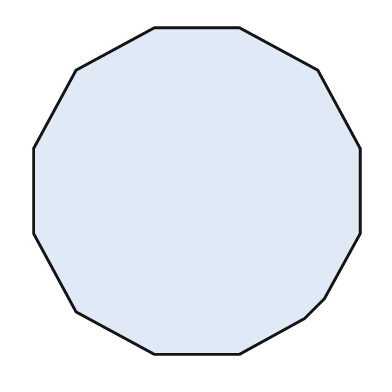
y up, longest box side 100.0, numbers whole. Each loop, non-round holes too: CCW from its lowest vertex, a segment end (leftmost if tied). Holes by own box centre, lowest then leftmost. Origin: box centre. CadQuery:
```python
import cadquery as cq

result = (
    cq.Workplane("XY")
    .moveTo(-13.0, -50.0)
    .lineTo(13.0, -50.0)
    .lineTo(33.0, -39.0)
    .lineTo(39.0, -33.0)
    .lineTo(50.0, -13.0)
    .lineTo(50.0, 13.0)
    .lineTo(37.0, 37.0)
    .lineTo(13.0, 50.0)
    .lineTo(-13.0, 50.0)
    .lineTo(-37.0, 37.0)
    .lineTo(-50.0, 13.0)
    .lineTo(-50.0, -13.0)
    .lineTo(-37.0, -37.0)
    .close()
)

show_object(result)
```